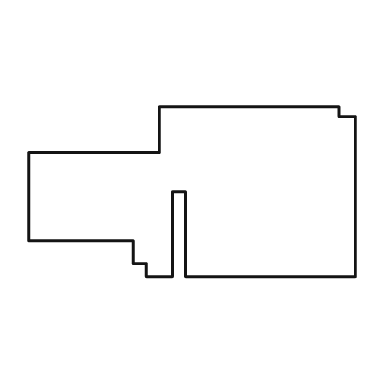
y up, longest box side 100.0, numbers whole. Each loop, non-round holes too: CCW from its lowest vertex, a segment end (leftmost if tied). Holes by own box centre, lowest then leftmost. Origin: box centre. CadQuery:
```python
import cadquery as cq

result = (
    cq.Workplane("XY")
    .moveTo(-14.0, -26.0)
    .lineTo(-6.0, -26.0)
    .lineTo(-6.0, 0.0)
    .lineTo(-2.0, 0.0)
    .lineTo(-2.0, -26.0)
    .lineTo(50.0, -26.0)
    .lineTo(50.0, 23.0)
    .lineTo(45.0, 23.0)
    .lineTo(45.0, 26.0)
    .lineTo(-10.0, 26.0)
    .lineTo(-10.0, 12.0)
    .lineTo(-50.0, 12.0)
    .lineTo(-50.0, -15.0)
    .lineTo(-18.0, -15.0)
    .lineTo(-18.0, -22.0)
    .lineTo(-14.0, -22.0)
    .close()
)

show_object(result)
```